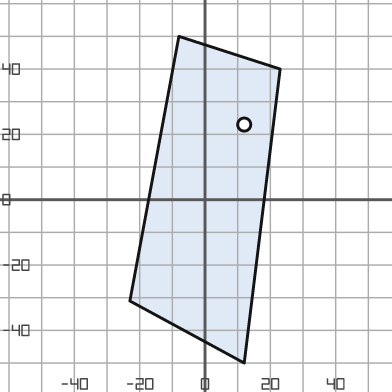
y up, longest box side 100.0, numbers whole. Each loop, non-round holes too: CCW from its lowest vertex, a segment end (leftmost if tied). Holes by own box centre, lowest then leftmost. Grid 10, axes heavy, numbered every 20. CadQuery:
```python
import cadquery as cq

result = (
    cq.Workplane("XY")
    .moveTo(12.0, -50.0)
    .lineTo(23.0, 40.0)
    .lineTo(-8.0, 50.0)
    .lineTo(-23.0, -31.0)
    .close()
    .moveTo(12.0, 23.0)
    .circle(2.0)
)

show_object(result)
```